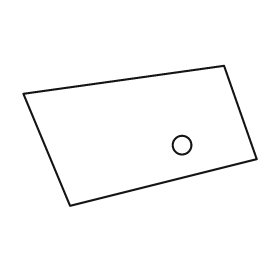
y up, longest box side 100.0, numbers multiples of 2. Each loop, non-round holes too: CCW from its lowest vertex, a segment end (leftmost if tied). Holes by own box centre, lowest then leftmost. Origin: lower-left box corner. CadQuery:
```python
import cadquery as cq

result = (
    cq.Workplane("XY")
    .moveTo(20.0, 0.0)
    .lineTo(100.0, 20.0)
    .lineTo(86.0, 60.0)
    .lineTo(0.0, 48.0)
    .close()
    .moveTo(68.0, 26.0)
    .circle(4.0)
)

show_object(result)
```